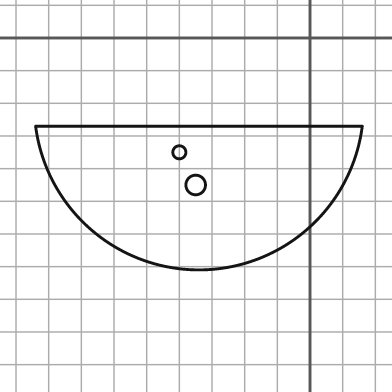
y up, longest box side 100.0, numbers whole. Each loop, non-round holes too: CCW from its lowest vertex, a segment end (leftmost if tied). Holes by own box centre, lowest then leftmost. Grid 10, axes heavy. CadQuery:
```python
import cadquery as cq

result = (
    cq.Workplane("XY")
    .moveTo(-84.0, -27.0)
    .threePointArc((-34.0, -71.0), (16.0, -27.0))
    .close()
    .moveTo(-35.0, -45.0)
    .circle(3.0)
    .moveTo(-40.0, -35.0)
    .circle(2.0)
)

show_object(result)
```